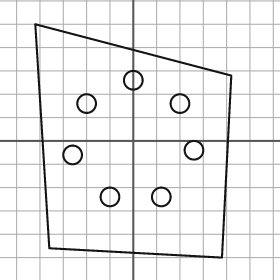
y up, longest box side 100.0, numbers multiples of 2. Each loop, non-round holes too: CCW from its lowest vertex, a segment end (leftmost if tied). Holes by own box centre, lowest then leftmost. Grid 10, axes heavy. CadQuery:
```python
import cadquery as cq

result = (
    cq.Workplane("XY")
    .moveTo(38.0, -50.0)
    .lineTo(42.0, 28.0)
    .lineTo(-42.0, 50.0)
    .lineTo(-36.0, -46.0)
    .close()
    .moveTo(-10.0, -24.0)
    .circle(4.0)
    .moveTo(12.0, -24.0)
    .circle(4.0)
    .moveTo(-26.0, -6.0)
    .circle(4.0)
    .moveTo(26.0, -4.0)
    .circle(4.0)
    .moveTo(-20.0, 16.0)
    .circle(4.0)
    .moveTo(20.0, 16.0)
    .circle(4.0)
    .moveTo(0.0, 26.0)
    .circle(4.0)
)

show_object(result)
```